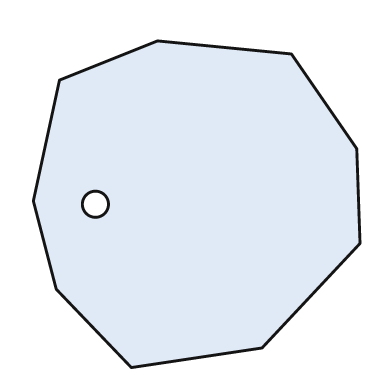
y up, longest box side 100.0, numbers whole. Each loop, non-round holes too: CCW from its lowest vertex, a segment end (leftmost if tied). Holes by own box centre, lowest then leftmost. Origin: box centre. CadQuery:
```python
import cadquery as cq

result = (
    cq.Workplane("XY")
    .moveTo(-20.0, -50.0)
    .lineTo(20.0, -44.0)
    .lineTo(50.0, -12.0)
    .lineTo(49.0, 17.0)
    .lineTo(29.0, 46.0)
    .lineTo(-12.0, 50.0)
    .lineTo(-42.0, 38.0)
    .lineTo(-50.0, 1.0)
    .lineTo(-43.0, -26.0)
    .close()
    .moveTo(-31.0, 0.0)
    .circle(4.0)
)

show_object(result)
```